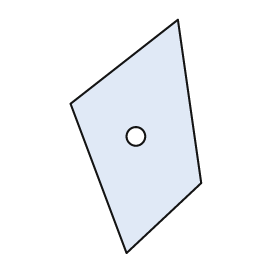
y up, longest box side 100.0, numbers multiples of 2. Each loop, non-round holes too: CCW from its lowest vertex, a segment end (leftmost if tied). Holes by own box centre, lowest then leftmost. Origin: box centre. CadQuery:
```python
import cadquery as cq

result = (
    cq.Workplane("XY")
    .moveTo(-4.0, -50.0)
    .lineTo(28.0, -20.0)
    .lineTo(18.0, 50.0)
    .lineTo(-28.0, 14.0)
    .close()
    .moveTo(0.0, 0.0)
    .circle(4.0)
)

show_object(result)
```